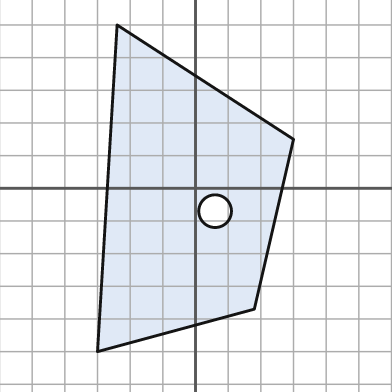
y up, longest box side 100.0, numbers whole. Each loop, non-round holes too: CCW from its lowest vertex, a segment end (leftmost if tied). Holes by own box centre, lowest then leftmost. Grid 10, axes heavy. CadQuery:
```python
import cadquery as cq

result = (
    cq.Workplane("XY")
    .moveTo(-30.0, -50.0)
    .lineTo(18.0, -37.0)
    .lineTo(30.0, 15.0)
    .lineTo(-24.0, 50.0)
    .close()
    .moveTo(6.0, -7.0)
    .circle(5.0)
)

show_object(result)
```